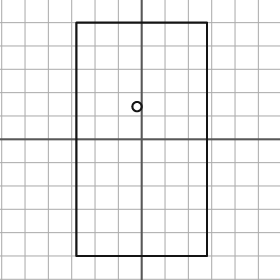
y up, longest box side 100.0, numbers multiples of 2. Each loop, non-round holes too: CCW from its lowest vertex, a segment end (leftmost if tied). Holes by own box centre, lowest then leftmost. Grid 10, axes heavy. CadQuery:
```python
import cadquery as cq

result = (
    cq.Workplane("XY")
    .moveTo(-28.0, -50.0)
    .lineTo(28.0, -50.0)
    .lineTo(28.0, 50.0)
    .lineTo(-28.0, 50.0)
    .close()
    .moveTo(-2.0, 14.0)
    .circle(2.0)
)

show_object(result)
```